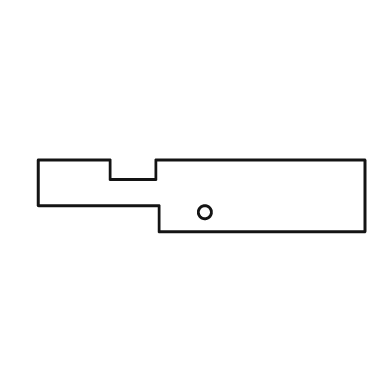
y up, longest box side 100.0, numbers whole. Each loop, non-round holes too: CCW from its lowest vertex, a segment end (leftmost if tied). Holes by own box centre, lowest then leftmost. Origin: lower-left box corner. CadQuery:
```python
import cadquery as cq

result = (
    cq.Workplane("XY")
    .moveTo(37.0, 0.0)
    .lineTo(100.0, 0.0)
    .lineTo(100.0, 22.0)
    .lineTo(36.0, 22.0)
    .lineTo(36.0, 16.0)
    .lineTo(22.0, 16.0)
    .lineTo(22.0, 22.0)
    .lineTo(0.0, 22.0)
    .lineTo(0.0, 8.0)
    .lineTo(37.0, 8.0)
    .close()
    .moveTo(51.0, 6.0)
    .circle(2.0)
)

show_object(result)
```